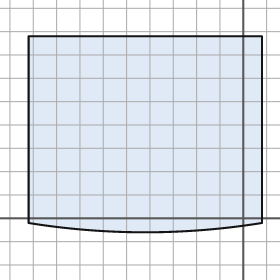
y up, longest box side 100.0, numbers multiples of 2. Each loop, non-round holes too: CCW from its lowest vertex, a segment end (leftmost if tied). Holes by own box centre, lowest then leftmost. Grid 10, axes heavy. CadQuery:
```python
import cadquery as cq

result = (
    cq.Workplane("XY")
    .moveTo(-92.0, -2.0)
    .threePointArc((-42.0, -6.0), (8.0, -2.0))
    .lineTo(8.0, 78.0)
    .lineTo(-92.0, 78.0)
    .close()
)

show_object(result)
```